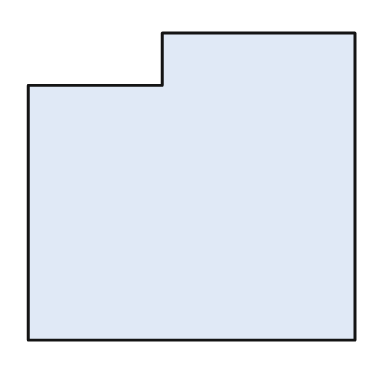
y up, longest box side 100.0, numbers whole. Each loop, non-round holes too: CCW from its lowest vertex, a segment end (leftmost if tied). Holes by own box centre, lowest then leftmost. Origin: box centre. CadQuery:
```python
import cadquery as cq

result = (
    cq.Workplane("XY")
    .moveTo(-50.0, -47.0)
    .lineTo(50.0, -47.0)
    .lineTo(50.0, 47.0)
    .lineTo(-9.0, 47.0)
    .lineTo(-9.0, 31.0)
    .lineTo(-50.0, 31.0)
    .close()
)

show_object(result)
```